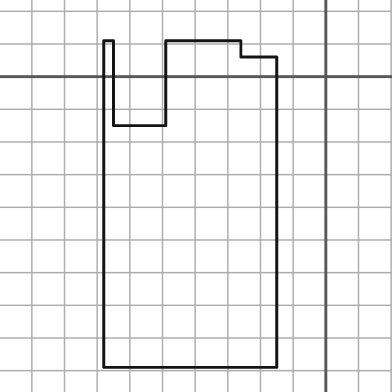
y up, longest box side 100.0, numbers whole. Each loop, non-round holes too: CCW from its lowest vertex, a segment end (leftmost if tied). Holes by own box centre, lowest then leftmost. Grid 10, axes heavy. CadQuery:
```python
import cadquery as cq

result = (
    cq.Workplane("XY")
    .moveTo(-68.0, -89.0)
    .lineTo(-15.0, -89.0)
    .lineTo(-15.0, 6.0)
    .lineTo(-26.0, 6.0)
    .lineTo(-26.0, 11.0)
    .lineTo(-49.0, 11.0)
    .lineTo(-49.0, -15.0)
    .lineTo(-65.0, -15.0)
    .lineTo(-65.0, 11.0)
    .lineTo(-68.0, 11.0)
    .close()
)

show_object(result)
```